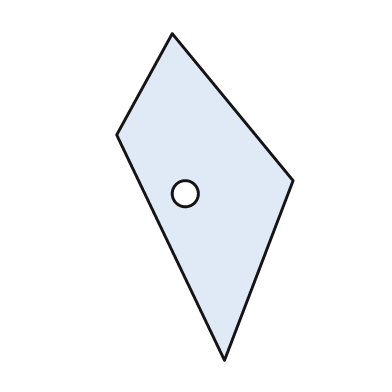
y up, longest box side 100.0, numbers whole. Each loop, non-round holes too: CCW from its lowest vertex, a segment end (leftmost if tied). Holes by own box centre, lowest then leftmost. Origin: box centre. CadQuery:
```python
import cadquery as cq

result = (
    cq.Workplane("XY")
    .moveTo(6.0, -50.0)
    .lineTo(27.0, 5.0)
    .lineTo(-10.0, 50.0)
    .lineTo(-27.0, 19.0)
    .close()
    .moveTo(-6.0, 1.0)
    .circle(4.0)
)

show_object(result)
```